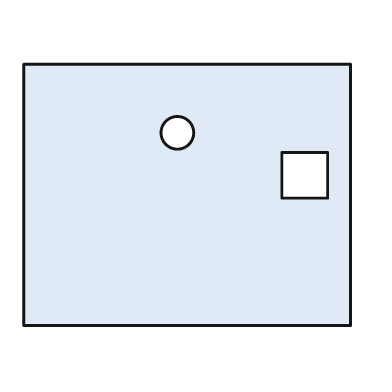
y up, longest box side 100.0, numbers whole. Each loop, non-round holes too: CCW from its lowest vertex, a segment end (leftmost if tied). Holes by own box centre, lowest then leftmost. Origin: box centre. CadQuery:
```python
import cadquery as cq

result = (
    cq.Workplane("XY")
    .moveTo(-50.0, -40.0)
    .lineTo(50.0, -40.0)
    .lineTo(50.0, 40.0)
    .lineTo(-50.0, 40.0)
    .close()
    .moveTo(29.0, -1.0)
    .lineTo(43.0, -1.0)
    .lineTo(43.0, 13.0)
    .lineTo(29.0, 13.0)
    .close()
    .moveTo(-3.0, 19.0)
    .circle(5.0)
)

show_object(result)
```